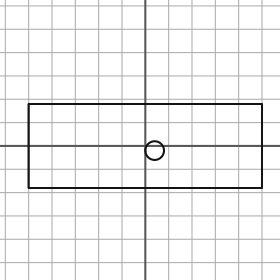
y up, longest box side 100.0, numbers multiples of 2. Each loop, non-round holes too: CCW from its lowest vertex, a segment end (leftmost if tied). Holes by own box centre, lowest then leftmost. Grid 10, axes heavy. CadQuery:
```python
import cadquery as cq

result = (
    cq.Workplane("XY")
    .moveTo(-50.0, -18.0)
    .lineTo(50.0, -18.0)
    .lineTo(50.0, 18.0)
    .lineTo(-50.0, 18.0)
    .close()
    .moveTo(4.0, -2.0)
    .circle(4.0)
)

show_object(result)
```